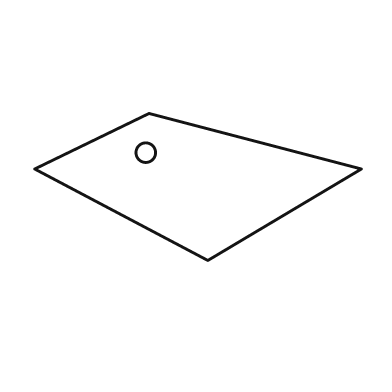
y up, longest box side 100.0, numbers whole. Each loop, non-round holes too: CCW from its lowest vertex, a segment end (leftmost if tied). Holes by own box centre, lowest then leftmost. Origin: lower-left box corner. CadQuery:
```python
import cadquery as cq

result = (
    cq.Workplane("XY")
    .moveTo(53.0, 0.0)
    .lineTo(100.0, 28.0)
    .lineTo(35.0, 45.0)
    .lineTo(0.0, 28.0)
    .close()
    .moveTo(34.0, 33.0)
    .circle(3.0)
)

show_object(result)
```